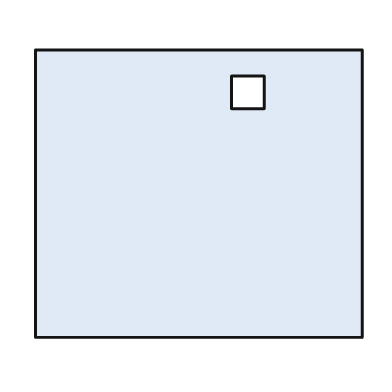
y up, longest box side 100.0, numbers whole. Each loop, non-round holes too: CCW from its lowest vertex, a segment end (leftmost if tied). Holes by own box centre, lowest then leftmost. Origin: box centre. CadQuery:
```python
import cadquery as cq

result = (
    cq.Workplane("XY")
    .moveTo(-50.0, -44.0)
    .lineTo(50.0, -44.0)
    .lineTo(50.0, 44.0)
    .lineTo(-50.0, 44.0)
    .close()
    .moveTo(10.0, 26.0)
    .lineTo(20.0, 26.0)
    .lineTo(20.0, 36.0)
    .lineTo(10.0, 36.0)
    .close()
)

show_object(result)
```